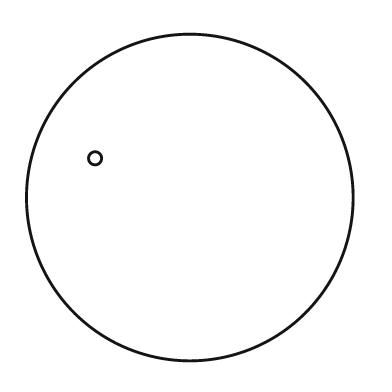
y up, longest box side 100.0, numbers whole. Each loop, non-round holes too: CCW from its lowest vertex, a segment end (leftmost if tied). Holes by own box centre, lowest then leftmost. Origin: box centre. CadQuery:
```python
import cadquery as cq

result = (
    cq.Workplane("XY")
    .moveTo(0.0, 0.0)
    .circle(50.0)
    .moveTo(-29.0, 12.0)
    .circle(2.0)
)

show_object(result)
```